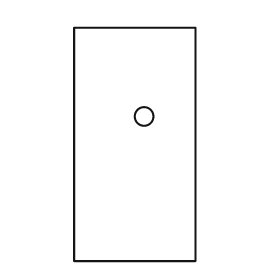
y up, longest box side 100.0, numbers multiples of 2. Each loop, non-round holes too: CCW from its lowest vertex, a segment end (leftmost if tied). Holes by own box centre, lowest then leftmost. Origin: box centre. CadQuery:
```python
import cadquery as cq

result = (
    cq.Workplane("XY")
    .moveTo(-26.0, -50.0)
    .lineTo(26.0, -50.0)
    .lineTo(26.0, 50.0)
    .lineTo(-26.0, 50.0)
    .close()
    .moveTo(4.0, 12.0)
    .circle(4.0)
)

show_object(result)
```